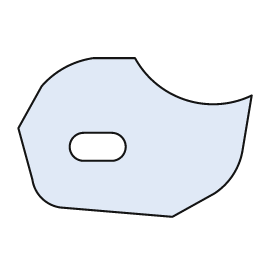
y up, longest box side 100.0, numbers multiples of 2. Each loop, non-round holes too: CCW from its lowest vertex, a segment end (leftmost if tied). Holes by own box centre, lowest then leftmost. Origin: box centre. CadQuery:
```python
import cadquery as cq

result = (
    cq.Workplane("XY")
    .moveTo(16.0, -34.0)
    .lineTo(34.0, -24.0)
    .threePointArc((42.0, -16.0), (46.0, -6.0))
    .lineTo(50.0, 18.0)
    .threePointArc((22.0, 16.0), (0.0, 34.0))
    .lineTo(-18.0, 34.0)
    .threePointArc((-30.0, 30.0), (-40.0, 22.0))
    .lineTo(-50.0, 4.0)
    .lineTo(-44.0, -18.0)
    .threePointArc((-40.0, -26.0), (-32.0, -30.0))
    .close()
    .moveTo(-22.0, -10.0)
    .lineTo(-10.0, -10.0)
    .threePointArc((-4.0, -4.0), (-10.0, 2.0))
    .lineTo(-22.0, 2.0)
    .threePointArc((-28.0, -4.0), (-22.0, -10.0))
    .close()
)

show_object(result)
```